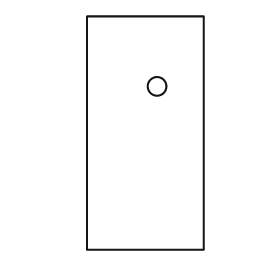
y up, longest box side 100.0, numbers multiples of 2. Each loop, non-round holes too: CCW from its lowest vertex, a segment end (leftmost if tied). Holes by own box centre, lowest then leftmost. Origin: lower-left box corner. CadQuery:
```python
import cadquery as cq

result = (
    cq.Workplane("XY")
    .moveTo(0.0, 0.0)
    .lineTo(50.0, 0.0)
    .lineTo(50.0, 100.0)
    .lineTo(0.0, 100.0)
    .close()
    .moveTo(30.0, 70.0)
    .circle(4.0)
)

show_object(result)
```